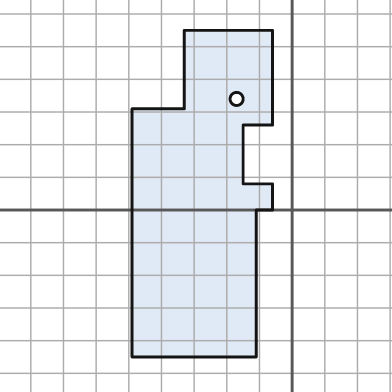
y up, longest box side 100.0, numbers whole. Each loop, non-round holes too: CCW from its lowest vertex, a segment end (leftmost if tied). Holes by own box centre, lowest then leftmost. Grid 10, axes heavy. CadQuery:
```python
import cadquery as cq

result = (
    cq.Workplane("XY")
    .moveTo(-49.0, -45.0)
    .lineTo(-11.0, -45.0)
    .lineTo(-11.0, 0.0)
    .lineTo(-6.0, 0.0)
    .lineTo(-6.0, 8.0)
    .lineTo(-15.0, 8.0)
    .lineTo(-15.0, 26.0)
    .lineTo(-6.0, 26.0)
    .lineTo(-6.0, 55.0)
    .lineTo(-33.0, 55.0)
    .lineTo(-33.0, 31.0)
    .lineTo(-49.0, 31.0)
    .close()
    .moveTo(-17.0, 34.0)
    .circle(2.0)
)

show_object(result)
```